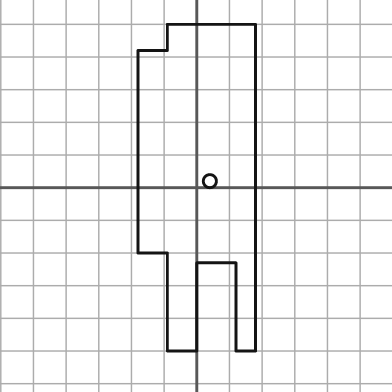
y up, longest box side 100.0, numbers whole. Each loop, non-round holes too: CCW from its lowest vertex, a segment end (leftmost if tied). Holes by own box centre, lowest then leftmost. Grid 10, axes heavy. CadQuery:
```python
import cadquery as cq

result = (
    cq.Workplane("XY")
    .moveTo(-9.0, -50.0)
    .lineTo(0.0, -50.0)
    .lineTo(0.0, -23.0)
    .lineTo(12.0, -23.0)
    .lineTo(12.0, -50.0)
    .lineTo(18.0, -50.0)
    .lineTo(18.0, 50.0)
    .lineTo(-9.0, 50.0)
    .lineTo(-9.0, 42.0)
    .lineTo(-18.0, 42.0)
    .lineTo(-18.0, -20.0)
    .lineTo(-9.0, -20.0)
    .close()
    .moveTo(4.0, 2.0)
    .circle(2.0)
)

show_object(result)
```